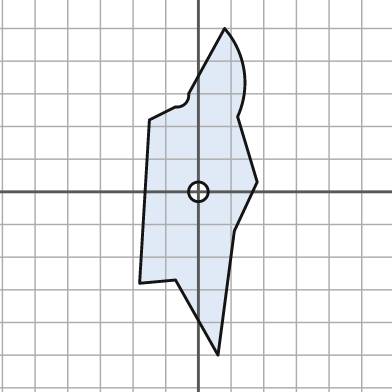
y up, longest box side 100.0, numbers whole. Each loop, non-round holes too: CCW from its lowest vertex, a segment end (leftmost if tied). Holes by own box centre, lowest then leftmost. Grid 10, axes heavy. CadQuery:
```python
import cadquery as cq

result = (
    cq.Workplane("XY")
    .moveTo(6.0, -50.0)
    .lineTo(11.0, -12.0)
    .lineTo(18.0, 3.0)
    .lineTo(12.0, 23.0)
    .threePointArc((14.0, 37.0), (8.0, 50.0))
    .lineTo(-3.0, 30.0)
    .threePointArc((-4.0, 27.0), (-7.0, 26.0))
    .lineTo(-15.0, 22.0)
    .lineTo(-18.0, -28.0)
    .lineTo(-7.0, -27.0)
    .close()
    .moveTo(0.0, 0.0)
    .circle(3.0)
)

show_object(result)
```